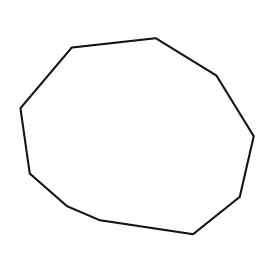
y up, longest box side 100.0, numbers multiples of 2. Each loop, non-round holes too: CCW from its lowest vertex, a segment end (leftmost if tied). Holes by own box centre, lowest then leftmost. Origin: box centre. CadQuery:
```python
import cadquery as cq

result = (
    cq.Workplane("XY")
    .moveTo(24.0, -42.0)
    .lineTo(44.0, -26.0)
    .lineTo(50.0, 0.0)
    .lineTo(34.0, 26.0)
    .lineTo(8.0, 42.0)
    .lineTo(-28.0, 38.0)
    .lineTo(-50.0, 12.0)
    .lineTo(-46.0, -16.0)
    .lineTo(-30.0, -30.0)
    .lineTo(-16.0, -36.0)
    .close()
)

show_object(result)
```